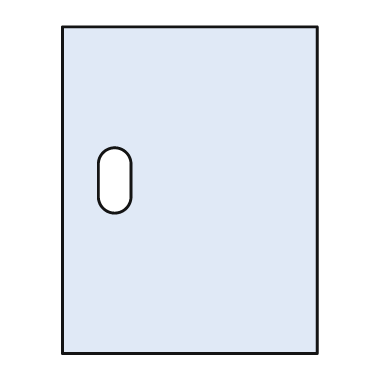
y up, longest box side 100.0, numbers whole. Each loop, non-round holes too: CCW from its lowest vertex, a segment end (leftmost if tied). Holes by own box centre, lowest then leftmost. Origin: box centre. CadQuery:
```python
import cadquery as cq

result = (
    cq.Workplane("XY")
    .moveTo(-39.0, -50.0)
    .lineTo(39.0, -50.0)
    .lineTo(39.0, 50.0)
    .lineTo(-39.0, 50.0)
    .close()
    .moveTo(-28.0, -2.0)
    .threePointArc((-23.0, -7.0), (-18.0, -2.0))
    .lineTo(-18.0, 8.0)
    .threePointArc((-23.0, 13.0), (-28.0, 8.0))
    .close()
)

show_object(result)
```